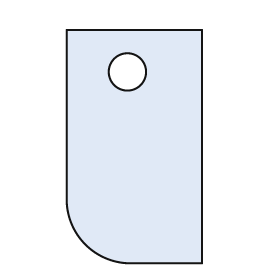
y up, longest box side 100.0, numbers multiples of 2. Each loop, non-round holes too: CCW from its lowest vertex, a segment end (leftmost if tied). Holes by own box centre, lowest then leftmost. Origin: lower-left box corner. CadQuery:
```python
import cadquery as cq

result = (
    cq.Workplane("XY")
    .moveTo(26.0, 0.0)
    .lineTo(58.0, 0.0)
    .lineTo(58.0, 100.0)
    .lineTo(0.0, 100.0)
    .lineTo(0.0, 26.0)
    .threePointArc((8.0, 8.0), (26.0, 0.0))
    .close()
    .moveTo(26.0, 82.0)
    .circle(8.0)
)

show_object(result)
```